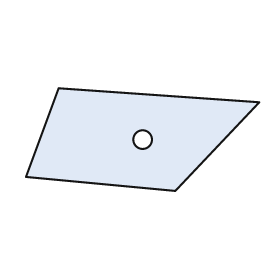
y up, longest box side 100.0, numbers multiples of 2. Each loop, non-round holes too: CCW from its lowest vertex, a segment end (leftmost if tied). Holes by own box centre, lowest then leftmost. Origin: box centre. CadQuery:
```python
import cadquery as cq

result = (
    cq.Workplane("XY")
    .moveTo(14.0, -22.0)
    .lineTo(50.0, 16.0)
    .lineTo(-36.0, 22.0)
    .lineTo(-50.0, -16.0)
    .close()
    .moveTo(0.0, 0.0)
    .circle(4.0)
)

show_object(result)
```